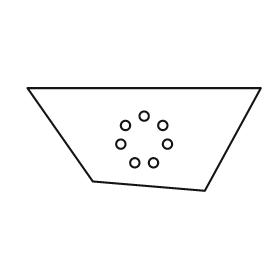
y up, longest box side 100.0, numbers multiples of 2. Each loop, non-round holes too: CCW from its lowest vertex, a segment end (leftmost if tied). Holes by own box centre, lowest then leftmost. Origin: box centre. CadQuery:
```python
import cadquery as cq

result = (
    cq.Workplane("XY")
    .moveTo(26.0, -22.0)
    .lineTo(50.0, 22.0)
    .lineTo(-50.0, 22.0)
    .lineTo(-22.0, -18.0)
    .close()
    .moveTo(-4.0, -10.0)
    .circle(2.0)
    .moveTo(4.0, -10.0)
    .circle(2.0)
    .moveTo(-10.0, -2.0)
    .circle(2.0)
    .moveTo(10.0, -2.0)
    .circle(2.0)
    .moveTo(-8.0, 6.0)
    .circle(2.0)
    .moveTo(8.0, 6.0)
    .circle(2.0)
    .moveTo(0.0, 10.0)
    .circle(2.0)
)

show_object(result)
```